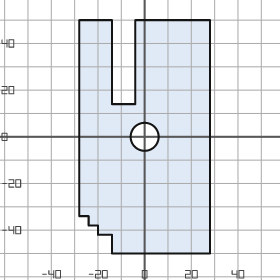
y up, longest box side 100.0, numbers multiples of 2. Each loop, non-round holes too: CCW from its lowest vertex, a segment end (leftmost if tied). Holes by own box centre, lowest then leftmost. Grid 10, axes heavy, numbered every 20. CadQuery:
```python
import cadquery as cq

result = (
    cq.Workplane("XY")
    .moveTo(-14.0, -50.0)
    .lineTo(28.0, -50.0)
    .lineTo(28.0, 50.0)
    .lineTo(-4.0, 50.0)
    .lineTo(-4.0, 14.0)
    .lineTo(-14.0, 14.0)
    .lineTo(-14.0, 50.0)
    .lineTo(-28.0, 50.0)
    .lineTo(-28.0, -34.0)
    .lineTo(-24.0, -34.0)
    .lineTo(-24.0, -38.0)
    .lineTo(-20.0, -38.0)
    .lineTo(-20.0, -42.0)
    .lineTo(-14.0, -42.0)
    .close()
    .moveTo(0.0, 0.0)
    .circle(6.0)
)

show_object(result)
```